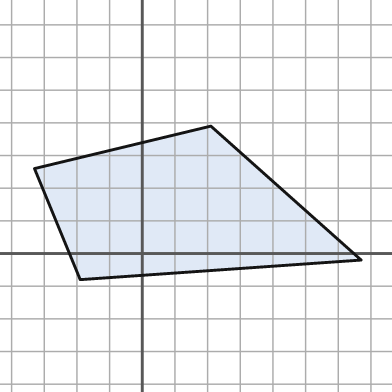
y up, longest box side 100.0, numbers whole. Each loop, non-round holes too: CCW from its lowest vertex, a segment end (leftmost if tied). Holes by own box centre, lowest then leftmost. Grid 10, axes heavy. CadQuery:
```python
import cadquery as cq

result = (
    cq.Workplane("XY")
    .moveTo(-19.0, -8.0)
    .lineTo(67.0, -2.0)
    .lineTo(21.0, 39.0)
    .lineTo(-33.0, 26.0)
    .close()
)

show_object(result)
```